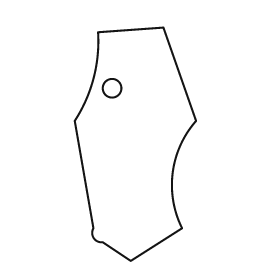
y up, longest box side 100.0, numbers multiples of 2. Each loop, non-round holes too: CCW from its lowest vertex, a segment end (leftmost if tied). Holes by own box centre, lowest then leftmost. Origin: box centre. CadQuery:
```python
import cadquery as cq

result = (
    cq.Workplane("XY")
    .moveTo(-2.0, -50.0)
    .lineTo(20.0, -36.0)
    .threePointArc((16.0, -12.0), (26.0, 10.0))
    .lineTo(12.0, 50.0)
    .lineTo(-16.0, 48.0)
    .threePointArc((-18.0, 28.0), (-26.0, 10.0))
    .lineTo(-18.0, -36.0)
    .threePointArc((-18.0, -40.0), (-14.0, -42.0))
    .close()
    .moveTo(-10.0, 24.0)
    .circle(4.0)
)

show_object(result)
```